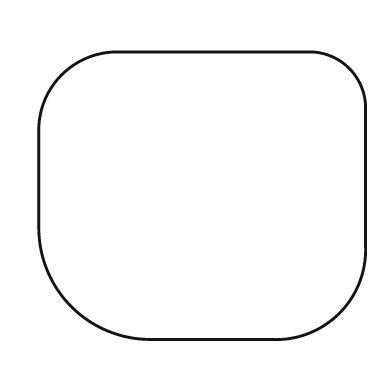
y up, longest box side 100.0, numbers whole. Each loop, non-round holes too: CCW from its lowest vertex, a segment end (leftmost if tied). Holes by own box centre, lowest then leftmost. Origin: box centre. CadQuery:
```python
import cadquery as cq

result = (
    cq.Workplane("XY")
    .moveTo(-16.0, -44.0)
    .lineTo(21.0, -44.0)
    .threePointArc((42.0, -36.0), (50.0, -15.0))
    .lineTo(50.0, 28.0)
    .threePointArc((45.0, 39.0), (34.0, 44.0))
    .lineTo(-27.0, 44.0)
    .threePointArc((-43.0, 37.0), (-50.0, 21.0))
    .lineTo(-50.0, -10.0)
    .threePointArc((-40.0, -34.0), (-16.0, -44.0))
    .close()
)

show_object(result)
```